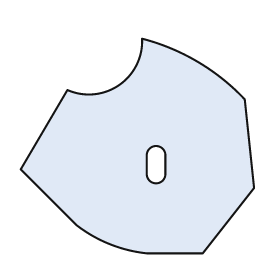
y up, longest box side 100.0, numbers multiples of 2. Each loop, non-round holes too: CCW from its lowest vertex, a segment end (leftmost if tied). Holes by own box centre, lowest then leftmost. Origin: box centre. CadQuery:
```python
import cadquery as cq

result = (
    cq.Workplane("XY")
    .moveTo(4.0, -46.0)
    .lineTo(28.0, -46.0)
    .lineTo(50.0, -18.0)
    .lineTo(46.0, 20.0)
    .threePointArc((26.0, 36.0), (2.0, 46.0))
    .threePointArc((-8.0, 26.0), (-30.0, 24.0))
    .lineTo(-50.0, -10.0)
    .lineTo(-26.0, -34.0)
    .threePointArc((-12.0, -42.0), (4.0, -46.0))
    .close()
    .moveTo(4.0, -12.0)
    .threePointArc((8.0, -16.0), (12.0, -12.0))
    .lineTo(12.0, -4.0)
    .threePointArc((8.0, 0.0), (4.0, -4.0))
    .close()
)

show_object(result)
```